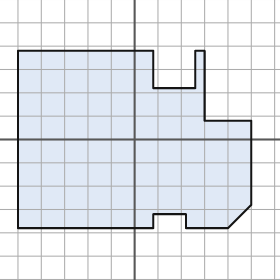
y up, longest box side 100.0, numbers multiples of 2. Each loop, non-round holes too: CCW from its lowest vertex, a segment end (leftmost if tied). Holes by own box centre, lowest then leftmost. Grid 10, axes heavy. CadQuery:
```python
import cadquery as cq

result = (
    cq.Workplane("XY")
    .moveTo(-50.0, -38.0)
    .lineTo(8.0, -38.0)
    .lineTo(8.0, -32.0)
    .lineTo(22.0, -32.0)
    .lineTo(22.0, -38.0)
    .lineTo(40.0, -38.0)
    .lineTo(50.0, -28.0)
    .lineTo(50.0, 8.0)
    .lineTo(30.0, 8.0)
    .lineTo(30.0, 38.0)
    .lineTo(26.0, 38.0)
    .lineTo(26.0, 22.0)
    .lineTo(8.0, 22.0)
    .lineTo(8.0, 38.0)
    .lineTo(-50.0, 38.0)
    .close()
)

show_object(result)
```